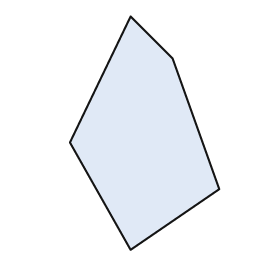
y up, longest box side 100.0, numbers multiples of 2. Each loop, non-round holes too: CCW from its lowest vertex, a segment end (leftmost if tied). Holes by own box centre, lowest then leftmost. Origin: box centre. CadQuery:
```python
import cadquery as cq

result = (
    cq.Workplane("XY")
    .moveTo(-6.0, -50.0)
    .lineTo(32.0, -24.0)
    .lineTo(12.0, 32.0)
    .lineTo(-6.0, 50.0)
    .lineTo(-32.0, -4.0)
    .close()
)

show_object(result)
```